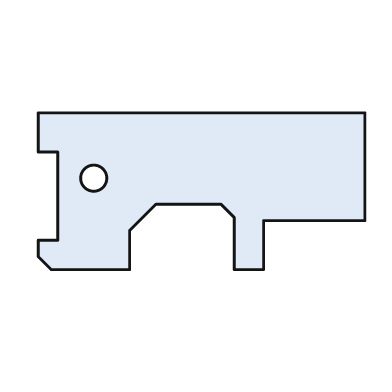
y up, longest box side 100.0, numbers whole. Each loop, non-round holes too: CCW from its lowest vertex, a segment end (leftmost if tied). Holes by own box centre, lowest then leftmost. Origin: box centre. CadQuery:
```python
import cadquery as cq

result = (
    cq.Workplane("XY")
    .moveTo(-46.0, -24.0)
    .lineTo(-22.0, -24.0)
    .lineTo(-22.0, -12.0)
    .lineTo(-14.0, -4.0)
    .lineTo(6.0, -4.0)
    .lineTo(10.0, -8.0)
    .lineTo(10.0, -24.0)
    .lineTo(19.0, -24.0)
    .lineTo(19.0, -9.0)
    .lineTo(50.0, -9.0)
    .lineTo(50.0, 24.0)
    .lineTo(-50.0, 24.0)
    .lineTo(-50.0, 12.0)
    .lineTo(-44.0, 12.0)
    .lineTo(-44.0, -15.0)
    .lineTo(-50.0, -15.0)
    .lineTo(-50.0, -20.0)
    .close()
    .moveTo(-33.0, 4.0)
    .circle(4.0)
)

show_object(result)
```